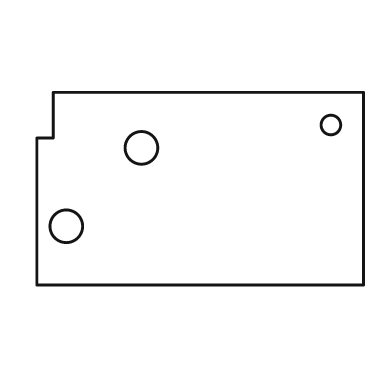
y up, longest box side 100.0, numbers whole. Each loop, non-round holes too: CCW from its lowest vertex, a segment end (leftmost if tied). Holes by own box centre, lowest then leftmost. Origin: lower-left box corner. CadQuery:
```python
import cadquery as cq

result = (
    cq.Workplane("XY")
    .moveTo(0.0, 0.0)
    .lineTo(100.0, 0.0)
    .lineTo(100.0, 59.0)
    .lineTo(5.0, 59.0)
    .lineTo(5.0, 45.0)
    .lineTo(0.0, 45.0)
    .close()
    .moveTo(9.0, 18.0)
    .circle(5.0)
    .moveTo(32.0, 42.0)
    .circle(5.0)
    .moveTo(90.0, 49.0)
    .circle(3.0)
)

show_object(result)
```